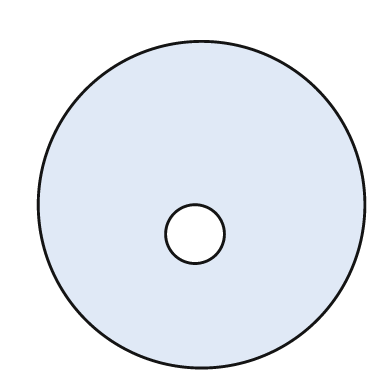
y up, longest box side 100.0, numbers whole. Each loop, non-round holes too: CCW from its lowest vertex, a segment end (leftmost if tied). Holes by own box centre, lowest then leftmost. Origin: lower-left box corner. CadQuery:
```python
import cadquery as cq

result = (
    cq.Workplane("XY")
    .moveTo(50.0, 50.0)
    .circle(50.0)
    .moveTo(48.0, 41.0)
    .circle(9.0)
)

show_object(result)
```